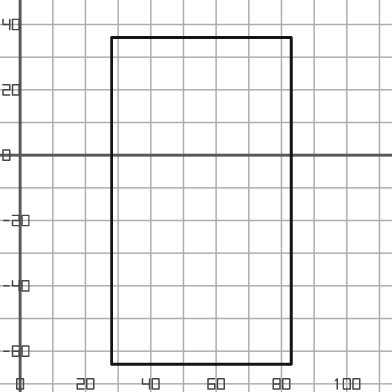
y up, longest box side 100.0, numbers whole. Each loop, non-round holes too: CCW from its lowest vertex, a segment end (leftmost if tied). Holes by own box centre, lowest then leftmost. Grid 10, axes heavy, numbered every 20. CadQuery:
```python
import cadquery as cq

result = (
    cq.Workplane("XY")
    .moveTo(28.0, -64.0)
    .lineTo(83.0, -64.0)
    .lineTo(83.0, 36.0)
    .lineTo(28.0, 36.0)
    .close()
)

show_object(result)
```